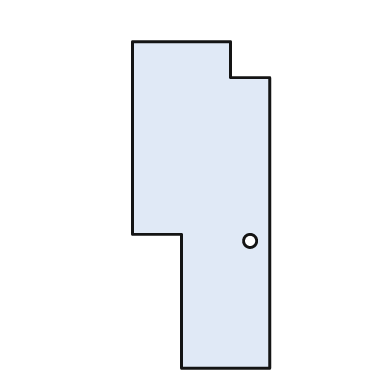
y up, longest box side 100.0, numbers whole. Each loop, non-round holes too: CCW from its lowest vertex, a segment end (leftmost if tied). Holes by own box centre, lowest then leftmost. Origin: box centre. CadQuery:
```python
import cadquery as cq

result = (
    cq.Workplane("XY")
    .moveTo(-6.0, -50.0)
    .lineTo(21.0, -50.0)
    .lineTo(21.0, 39.0)
    .lineTo(9.0, 39.0)
    .lineTo(9.0, 50.0)
    .lineTo(-21.0, 50.0)
    .lineTo(-21.0, -9.0)
    .lineTo(-6.0, -9.0)
    .close()
    .moveTo(15.0, -11.0)
    .circle(2.0)
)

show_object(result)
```